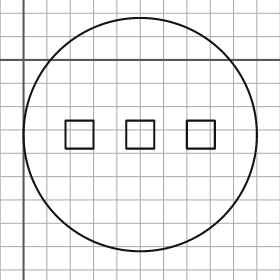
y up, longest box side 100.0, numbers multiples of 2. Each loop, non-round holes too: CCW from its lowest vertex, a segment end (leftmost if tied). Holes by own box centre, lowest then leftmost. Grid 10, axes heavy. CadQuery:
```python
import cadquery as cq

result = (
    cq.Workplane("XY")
    .moveTo(50.0, -32.0)
    .circle(50.0)
    .moveTo(18.0, -38.0)
    .lineTo(30.0, -38.0)
    .lineTo(30.0, -26.0)
    .lineTo(18.0, -26.0)
    .close()
    .moveTo(44.0, -38.0)
    .lineTo(56.0, -38.0)
    .lineTo(56.0, -26.0)
    .lineTo(44.0, -26.0)
    .close()
    .moveTo(70.0, -38.0)
    .lineTo(82.0, -38.0)
    .lineTo(82.0, -26.0)
    .lineTo(70.0, -26.0)
    .close()
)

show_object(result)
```